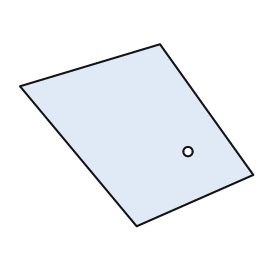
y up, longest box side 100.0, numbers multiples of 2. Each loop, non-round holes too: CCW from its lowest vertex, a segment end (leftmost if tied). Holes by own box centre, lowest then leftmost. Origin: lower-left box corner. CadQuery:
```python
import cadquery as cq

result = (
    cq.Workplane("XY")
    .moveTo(50.0, 0.0)
    .lineTo(100.0, 22.0)
    .lineTo(60.0, 78.0)
    .lineTo(0.0, 60.0)
    .close()
    .moveTo(72.0, 32.0)
    .circle(2.0)
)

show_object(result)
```